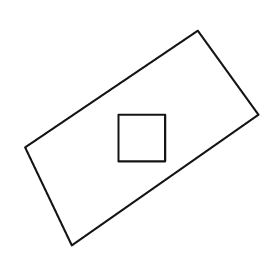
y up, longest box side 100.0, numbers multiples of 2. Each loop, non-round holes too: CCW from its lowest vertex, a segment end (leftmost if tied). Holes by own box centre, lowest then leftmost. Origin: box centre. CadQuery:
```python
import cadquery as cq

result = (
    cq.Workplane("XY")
    .moveTo(-30.0, -46.0)
    .lineTo(50.0, 10.0)
    .lineTo(24.0, 46.0)
    .lineTo(-50.0, -4.0)
    .close()
    .moveTo(-10.0, -10.0)
    .lineTo(10.0, -10.0)
    .lineTo(10.0, 10.0)
    .lineTo(-10.0, 10.0)
    .close()
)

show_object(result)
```